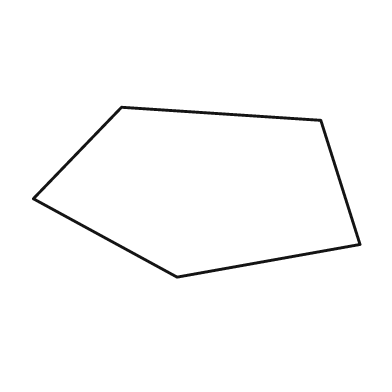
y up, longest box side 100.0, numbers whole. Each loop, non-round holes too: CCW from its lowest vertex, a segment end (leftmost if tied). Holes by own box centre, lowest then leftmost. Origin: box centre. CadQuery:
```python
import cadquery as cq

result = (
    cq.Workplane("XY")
    .moveTo(-6.0, -26.0)
    .lineTo(50.0, -16.0)
    .lineTo(38.0, 22.0)
    .lineTo(-23.0, 26.0)
    .lineTo(-50.0, -2.0)
    .close()
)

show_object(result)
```